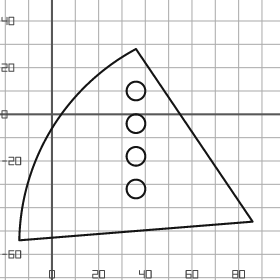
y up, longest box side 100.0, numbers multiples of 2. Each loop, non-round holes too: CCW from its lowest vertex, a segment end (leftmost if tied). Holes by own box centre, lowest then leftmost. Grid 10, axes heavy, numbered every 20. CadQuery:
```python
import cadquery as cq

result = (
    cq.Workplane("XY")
    .moveTo(-14.0, -54.0)
    .lineTo(86.0, -46.0)
    .lineTo(36.0, 28.0)
    .threePointArc((0.0, -6.0), (-14.0, -54.0))
    .close()
    .moveTo(36.0, -32.0)
    .circle(4.0)
    .moveTo(36.0, -18.0)
    .circle(4.0)
    .moveTo(36.0, -4.0)
    .circle(4.0)
    .moveTo(36.0, 10.0)
    .circle(4.0)
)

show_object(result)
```